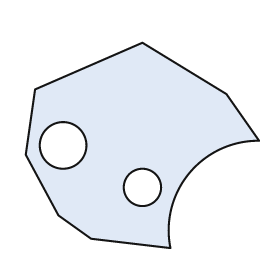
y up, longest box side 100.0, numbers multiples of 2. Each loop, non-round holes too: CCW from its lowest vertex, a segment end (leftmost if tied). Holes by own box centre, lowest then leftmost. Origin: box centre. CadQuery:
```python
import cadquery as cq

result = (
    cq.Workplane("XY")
    .moveTo(12.0, -44.0)
    .threePointArc((20.0, -12.0), (50.0, 2.0))
    .lineTo(36.0, 22.0)
    .lineTo(0.0, 44.0)
    .lineTo(-46.0, 24.0)
    .lineTo(-50.0, -4.0)
    .lineTo(-36.0, -30.0)
    .lineTo(-22.0, -40.0)
    .close()
    .moveTo(0.0, -18.0)
    .circle(8.0)
    .moveTo(-34.0, 0.0)
    .circle(10.0)
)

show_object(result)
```